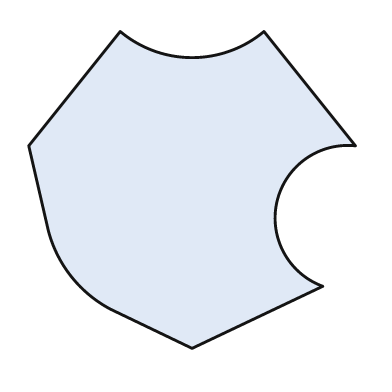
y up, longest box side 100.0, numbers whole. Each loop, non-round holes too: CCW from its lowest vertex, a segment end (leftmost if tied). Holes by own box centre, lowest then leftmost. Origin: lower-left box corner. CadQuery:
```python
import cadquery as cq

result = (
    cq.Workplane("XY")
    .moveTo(50.0, 0.0)
    .lineTo(90.0, 19.0)
    .threePointArc((76.0, 45.0), (100.0, 62.0))
    .lineTo(72.0, 97.0)
    .threePointArc((50.0, 89.0), (28.0, 97.0))
    .lineTo(0.0, 62.0)
    .lineTo(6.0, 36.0)
    .threePointArc((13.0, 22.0), (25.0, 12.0))
    .close()
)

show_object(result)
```